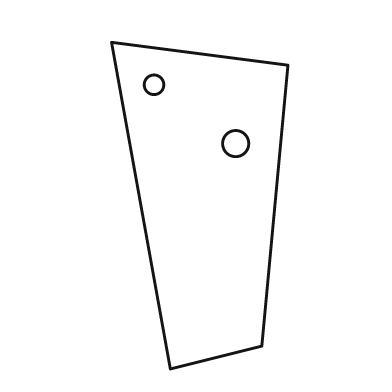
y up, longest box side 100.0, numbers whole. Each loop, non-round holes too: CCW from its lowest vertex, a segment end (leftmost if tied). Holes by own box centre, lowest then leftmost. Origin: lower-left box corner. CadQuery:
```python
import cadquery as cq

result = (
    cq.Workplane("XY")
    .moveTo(18.0, 0.0)
    .lineTo(46.0, 7.0)
    .lineTo(54.0, 93.0)
    .lineTo(0.0, 100.0)
    .close()
    .moveTo(38.0, 69.0)
    .circle(4.0)
    .moveTo(13.0, 87.0)
    .circle(3.0)
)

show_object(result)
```